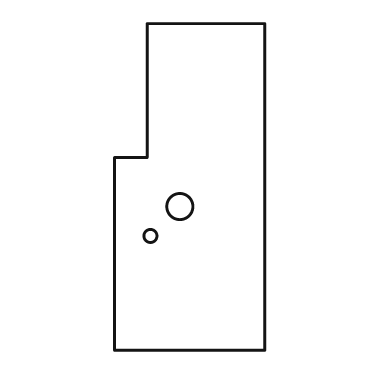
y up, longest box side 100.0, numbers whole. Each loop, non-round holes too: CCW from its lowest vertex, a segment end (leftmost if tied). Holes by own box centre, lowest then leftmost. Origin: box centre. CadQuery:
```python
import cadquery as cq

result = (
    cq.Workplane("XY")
    .moveTo(-23.0, -50.0)
    .lineTo(23.0, -50.0)
    .lineTo(23.0, 50.0)
    .lineTo(-13.0, 50.0)
    .lineTo(-13.0, 9.0)
    .lineTo(-23.0, 9.0)
    .close()
    .moveTo(-12.0, -15.0)
    .circle(2.0)
    .moveTo(-3.0, -6.0)
    .circle(4.0)
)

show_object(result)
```